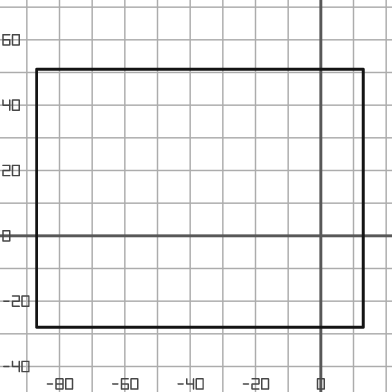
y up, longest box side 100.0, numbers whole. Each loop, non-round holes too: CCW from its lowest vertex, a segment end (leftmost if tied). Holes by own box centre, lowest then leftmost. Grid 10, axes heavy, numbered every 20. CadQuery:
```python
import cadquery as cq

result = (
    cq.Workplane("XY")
    .moveTo(-87.0, -28.0)
    .lineTo(13.0, -28.0)
    .lineTo(13.0, 51.0)
    .lineTo(-87.0, 51.0)
    .close()
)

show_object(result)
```